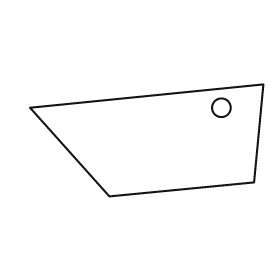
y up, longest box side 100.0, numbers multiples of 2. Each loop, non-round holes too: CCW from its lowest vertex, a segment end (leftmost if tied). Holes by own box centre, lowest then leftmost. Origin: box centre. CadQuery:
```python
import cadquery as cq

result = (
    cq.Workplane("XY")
    .moveTo(-16.0, -24.0)
    .lineTo(46.0, -18.0)
    .lineTo(50.0, 24.0)
    .lineTo(-50.0, 14.0)
    .close()
    .moveTo(32.0, 14.0)
    .circle(4.0)
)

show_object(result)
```